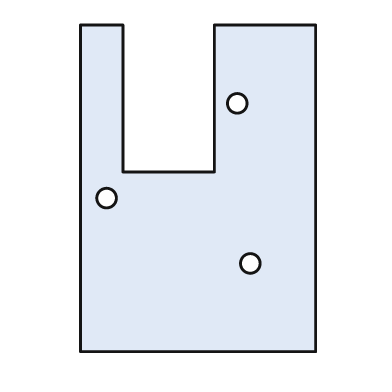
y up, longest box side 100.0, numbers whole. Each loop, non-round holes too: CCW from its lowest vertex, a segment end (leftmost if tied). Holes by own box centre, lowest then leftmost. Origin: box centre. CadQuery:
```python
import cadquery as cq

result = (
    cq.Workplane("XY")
    .moveTo(-36.0, -50.0)
    .lineTo(36.0, -50.0)
    .lineTo(36.0, 50.0)
    .lineTo(5.0, 50.0)
    .lineTo(5.0, 5.0)
    .lineTo(-23.0, 5.0)
    .lineTo(-23.0, 50.0)
    .lineTo(-36.0, 50.0)
    .close()
    .moveTo(16.0, -23.0)
    .circle(3.0)
    .moveTo(-28.0, -3.0)
    .circle(3.0)
    .moveTo(12.0, 26.0)
    .circle(3.0)
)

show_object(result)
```